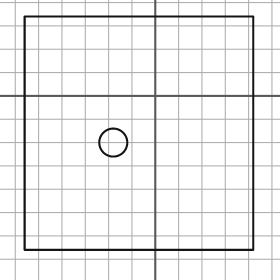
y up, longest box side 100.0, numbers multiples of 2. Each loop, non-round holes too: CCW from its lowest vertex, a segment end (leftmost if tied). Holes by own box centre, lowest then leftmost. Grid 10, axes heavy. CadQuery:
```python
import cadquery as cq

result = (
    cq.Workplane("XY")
    .moveTo(-56.0, -66.0)
    .lineTo(42.0, -66.0)
    .lineTo(42.0, 34.0)
    .lineTo(-56.0, 34.0)
    .close()
    .moveTo(-18.0, -20.0)
    .circle(6.0)
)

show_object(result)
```